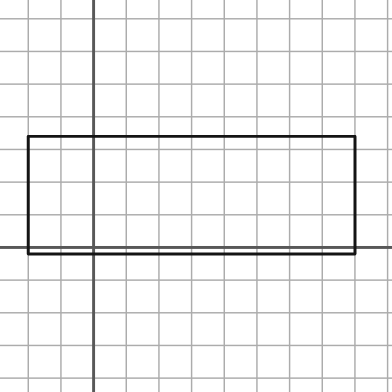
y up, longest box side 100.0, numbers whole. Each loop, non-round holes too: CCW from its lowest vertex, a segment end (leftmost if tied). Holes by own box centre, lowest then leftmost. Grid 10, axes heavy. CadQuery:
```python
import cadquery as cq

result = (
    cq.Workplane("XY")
    .moveTo(-20.0, -2.0)
    .lineTo(80.0, -2.0)
    .lineTo(80.0, 34.0)
    .lineTo(-20.0, 34.0)
    .close()
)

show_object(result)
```